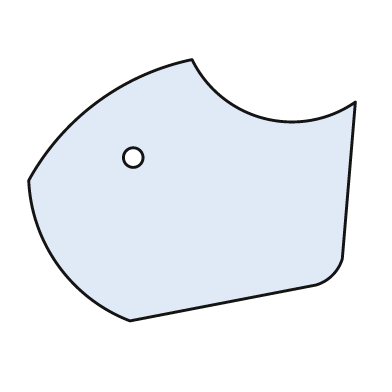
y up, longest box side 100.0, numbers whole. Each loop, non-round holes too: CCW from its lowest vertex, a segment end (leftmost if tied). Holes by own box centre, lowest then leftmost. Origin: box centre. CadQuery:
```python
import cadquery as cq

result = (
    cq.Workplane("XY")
    .moveTo(-19.0, -40.0)
    .lineTo(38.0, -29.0)
    .threePointArc((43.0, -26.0), (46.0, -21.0))
    .lineTo(50.0, 27.0)
    .threePointArc((22.0, 22.0), (0.0, 40.0))
    .threePointArc((-29.0, 27.0), (-50.0, 3.0))
    .threePointArc((-41.0, -23.0), (-19.0, -40.0))
    .close()
    .moveTo(-18.0, 10.0)
    .circle(3.0)
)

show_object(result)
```